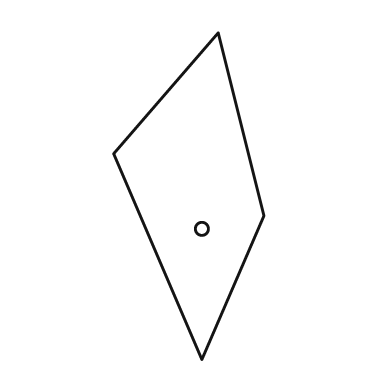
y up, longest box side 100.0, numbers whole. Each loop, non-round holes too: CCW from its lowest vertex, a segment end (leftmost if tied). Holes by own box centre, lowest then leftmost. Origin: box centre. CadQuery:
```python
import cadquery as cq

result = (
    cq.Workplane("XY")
    .moveTo(4.0, -50.0)
    .lineTo(23.0, -6.0)
    .lineTo(9.0, 50.0)
    .lineTo(-23.0, 13.0)
    .close()
    .moveTo(4.0, -10.0)
    .circle(2.0)
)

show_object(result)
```